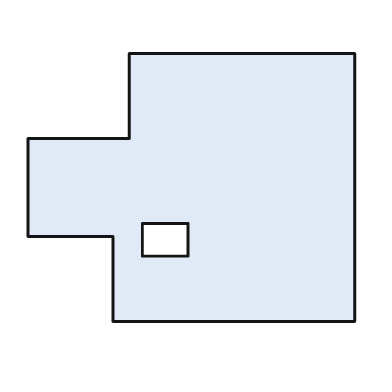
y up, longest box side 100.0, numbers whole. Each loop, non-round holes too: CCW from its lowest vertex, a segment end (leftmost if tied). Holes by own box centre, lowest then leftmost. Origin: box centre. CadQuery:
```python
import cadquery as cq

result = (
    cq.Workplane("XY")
    .moveTo(-24.0, -41.0)
    .lineTo(50.0, -41.0)
    .lineTo(50.0, 41.0)
    .lineTo(-19.0, 41.0)
    .lineTo(-19.0, 15.0)
    .lineTo(-50.0, 15.0)
    .lineTo(-50.0, -15.0)
    .lineTo(-24.0, -15.0)
    .close()
    .moveTo(-15.0, -21.0)
    .lineTo(-1.0, -21.0)
    .lineTo(-1.0, -11.0)
    .lineTo(-15.0, -11.0)
    .close()
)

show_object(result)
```